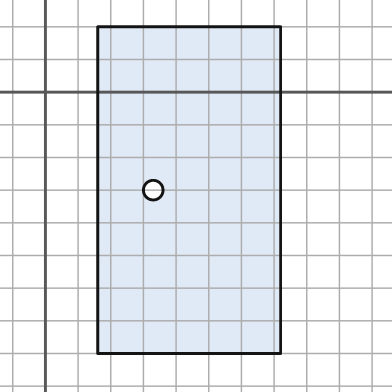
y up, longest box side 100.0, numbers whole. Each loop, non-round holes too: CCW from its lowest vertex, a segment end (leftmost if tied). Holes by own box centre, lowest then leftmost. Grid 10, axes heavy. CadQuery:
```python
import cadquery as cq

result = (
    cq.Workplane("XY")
    .moveTo(16.0, -80.0)
    .lineTo(72.0, -80.0)
    .lineTo(72.0, 20.0)
    .lineTo(16.0, 20.0)
    .close()
    .moveTo(33.0, -30.0)
    .circle(3.0)
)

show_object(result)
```